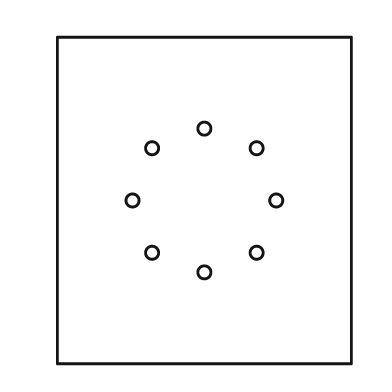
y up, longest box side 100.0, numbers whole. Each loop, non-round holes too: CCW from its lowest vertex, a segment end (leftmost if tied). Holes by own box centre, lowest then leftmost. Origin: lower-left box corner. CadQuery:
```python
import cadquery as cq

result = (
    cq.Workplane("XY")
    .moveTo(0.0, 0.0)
    .lineTo(90.0, 0.0)
    .lineTo(90.0, 100.0)
    .lineTo(0.0, 100.0)
    .close()
    .moveTo(45.0, 28.0)
    .circle(2.0)
    .moveTo(29.0, 34.0)
    .circle(2.0)
    .moveTo(61.0, 34.0)
    .circle(2.0)
    .moveTo(23.0, 50.0)
    .circle(2.0)
    .moveTo(67.0, 50.0)
    .circle(2.0)
    .moveTo(29.0, 66.0)
    .circle(2.0)
    .moveTo(61.0, 66.0)
    .circle(2.0)
    .moveTo(45.0, 72.0)
    .circle(2.0)
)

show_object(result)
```